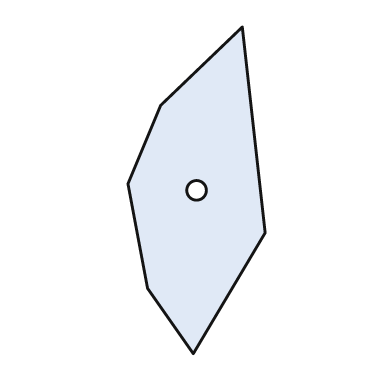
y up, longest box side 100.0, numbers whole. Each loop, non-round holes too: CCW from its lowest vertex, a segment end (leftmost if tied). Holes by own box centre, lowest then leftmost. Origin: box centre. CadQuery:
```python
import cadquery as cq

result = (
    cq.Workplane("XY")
    .moveTo(-1.0, -50.0)
    .lineTo(21.0, -13.0)
    .lineTo(14.0, 50.0)
    .lineTo(-11.0, 26.0)
    .lineTo(-21.0, 2.0)
    .lineTo(-15.0, -30.0)
    .close()
    .moveTo(0.0, 0.0)
    .circle(3.0)
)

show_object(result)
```